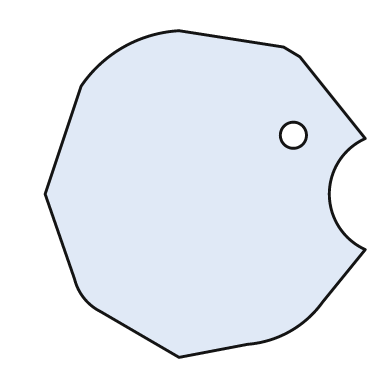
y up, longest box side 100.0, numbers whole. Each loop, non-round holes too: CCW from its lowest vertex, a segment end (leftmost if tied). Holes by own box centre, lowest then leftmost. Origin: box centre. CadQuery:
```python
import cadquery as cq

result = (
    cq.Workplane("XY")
    .moveTo(-8.0, -50.0)
    .lineTo(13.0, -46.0)
    .threePointArc((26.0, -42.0), (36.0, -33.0))
    .lineTo(49.0, -17.0)
    .threePointArc((38.0, 0.0), (49.0, 17.0))
    .lineTo(29.0, 42.0)
    .lineTo(24.0, 45.0)
    .lineTo(-8.0, 50.0)
    .threePointArc((-25.0, 45.0), (-38.0, 33.0))
    .lineTo(-49.0, 0.0)
    .lineTo(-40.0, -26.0)
    .threePointArc((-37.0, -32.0), (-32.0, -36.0))
    .close()
    .moveTo(27.0, 18.0)
    .circle(4.0)
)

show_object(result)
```